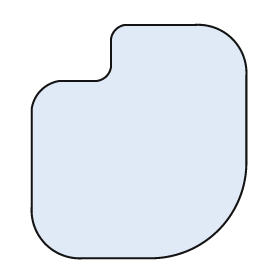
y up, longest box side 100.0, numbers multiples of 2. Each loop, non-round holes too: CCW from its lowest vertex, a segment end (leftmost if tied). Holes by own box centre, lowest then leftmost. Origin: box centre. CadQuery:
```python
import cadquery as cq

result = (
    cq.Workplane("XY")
    .moveTo(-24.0, -50.0)
    .lineTo(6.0, -50.0)
    .threePointArc((34.0, -38.0), (46.0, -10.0))
    .lineTo(46.0, 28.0)
    .threePointArc((40.0, 44.0), (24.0, 50.0))
    .lineTo(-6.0, 50.0)
    .threePointArc((-10.0, 48.0), (-12.0, 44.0))
    .lineTo(-12.0, 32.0)
    .threePointArc((-14.0, 28.0), (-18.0, 26.0))
    .lineTo(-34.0, 26.0)
    .threePointArc((-42.0, 22.0), (-46.0, 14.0))
    .lineTo(-46.0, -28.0)
    .threePointArc((-40.0, -44.0), (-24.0, -50.0))
    .close()
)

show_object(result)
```